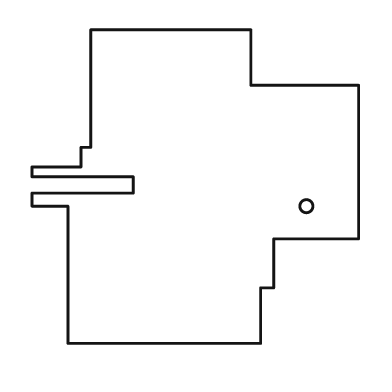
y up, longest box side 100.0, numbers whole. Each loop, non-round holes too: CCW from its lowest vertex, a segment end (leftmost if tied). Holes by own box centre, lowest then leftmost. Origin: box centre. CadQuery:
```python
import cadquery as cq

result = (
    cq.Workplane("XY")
    .moveTo(-39.0, -48.0)
    .lineTo(20.0, -48.0)
    .lineTo(20.0, -31.0)
    .lineTo(24.0, -31.0)
    .lineTo(24.0, -16.0)
    .lineTo(50.0, -16.0)
    .lineTo(50.0, 31.0)
    .lineTo(17.0, 31.0)
    .lineTo(17.0, 48.0)
    .lineTo(-32.0, 48.0)
    .lineTo(-32.0, 12.0)
    .lineTo(-35.0, 12.0)
    .lineTo(-35.0, 6.0)
    .lineTo(-50.0, 6.0)
    .lineTo(-50.0, 3.0)
    .lineTo(-19.0, 3.0)
    .lineTo(-19.0, -2.0)
    .lineTo(-50.0, -2.0)
    .lineTo(-50.0, -6.0)
    .lineTo(-39.0, -6.0)
    .close()
    .moveTo(34.0, -6.0)
    .circle(2.0)
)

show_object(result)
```